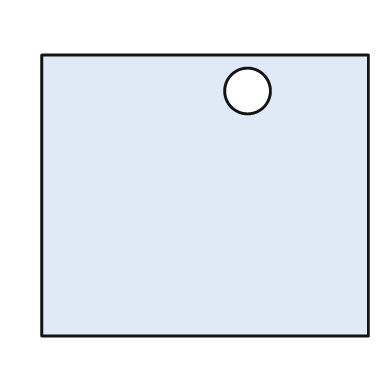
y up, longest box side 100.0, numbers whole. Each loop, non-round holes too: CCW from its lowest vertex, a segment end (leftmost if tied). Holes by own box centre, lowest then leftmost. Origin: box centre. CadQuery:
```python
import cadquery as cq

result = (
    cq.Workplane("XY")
    .moveTo(-50.0, -43.0)
    .lineTo(50.0, -43.0)
    .lineTo(50.0, 43.0)
    .lineTo(-50.0, 43.0)
    .close()
    .moveTo(13.0, 32.0)
    .circle(7.0)
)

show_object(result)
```